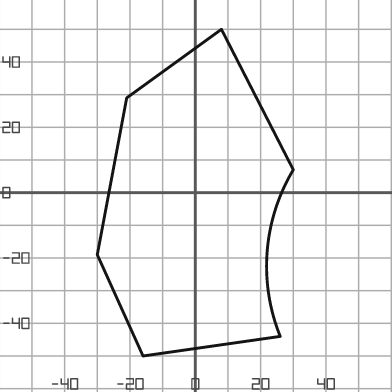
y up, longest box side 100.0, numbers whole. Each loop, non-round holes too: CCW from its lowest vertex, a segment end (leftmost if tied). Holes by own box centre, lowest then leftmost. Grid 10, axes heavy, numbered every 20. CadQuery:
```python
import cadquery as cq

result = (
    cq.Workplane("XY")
    .moveTo(-16.0, -50.0)
    .lineTo(26.0, -44.0)
    .threePointArc((22.0, -18.0), (30.0, 7.0))
    .lineTo(8.0, 50.0)
    .lineTo(-21.0, 29.0)
    .lineTo(-30.0, -19.0)
    .close()
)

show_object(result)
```